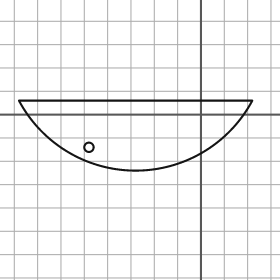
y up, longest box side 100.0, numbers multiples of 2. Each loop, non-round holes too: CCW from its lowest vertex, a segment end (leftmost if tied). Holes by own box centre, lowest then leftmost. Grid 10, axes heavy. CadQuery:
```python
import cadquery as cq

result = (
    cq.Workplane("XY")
    .moveTo(-78.0, 6.0)
    .threePointArc((-28.0, -24.0), (22.0, 6.0))
    .close()
    .moveTo(-48.0, -14.0)
    .circle(2.0)
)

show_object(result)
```